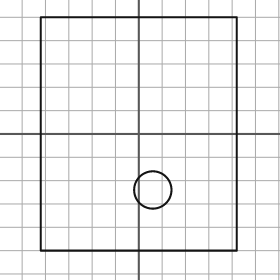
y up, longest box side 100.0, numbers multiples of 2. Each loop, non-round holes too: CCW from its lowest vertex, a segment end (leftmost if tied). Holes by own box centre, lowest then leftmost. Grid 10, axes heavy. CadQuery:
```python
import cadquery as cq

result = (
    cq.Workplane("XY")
    .moveTo(-42.0, -50.0)
    .lineTo(42.0, -50.0)
    .lineTo(42.0, 50.0)
    .lineTo(-42.0, 50.0)
    .close()
    .moveTo(6.0, -24.0)
    .circle(8.0)
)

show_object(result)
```